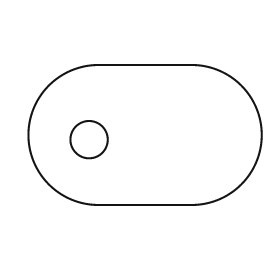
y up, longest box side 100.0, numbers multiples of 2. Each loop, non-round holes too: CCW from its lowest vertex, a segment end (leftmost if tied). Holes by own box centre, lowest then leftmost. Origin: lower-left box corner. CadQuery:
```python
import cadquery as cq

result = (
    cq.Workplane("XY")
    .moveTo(30.0, 0.0)
    .lineTo(70.0, 0.0)
    .threePointArc((100.0, 30.0), (70.0, 60.0))
    .lineTo(30.0, 60.0)
    .threePointArc((0.0, 30.0), (30.0, 0.0))
    .close()
    .moveTo(26.0, 28.0)
    .circle(8.0)
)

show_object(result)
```